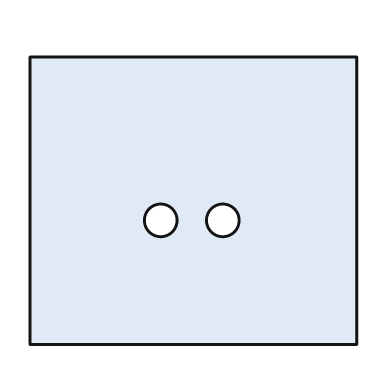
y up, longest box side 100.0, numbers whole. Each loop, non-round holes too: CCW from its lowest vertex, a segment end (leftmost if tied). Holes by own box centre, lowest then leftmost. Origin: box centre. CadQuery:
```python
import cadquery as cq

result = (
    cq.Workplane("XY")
    .moveTo(-50.0, -44.0)
    .lineTo(50.0, -44.0)
    .lineTo(50.0, 44.0)
    .lineTo(-50.0, 44.0)
    .close()
    .moveTo(-10.0, -6.0)
    .circle(5.0)
    .moveTo(9.0, -6.0)
    .circle(5.0)
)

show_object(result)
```